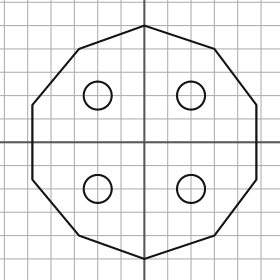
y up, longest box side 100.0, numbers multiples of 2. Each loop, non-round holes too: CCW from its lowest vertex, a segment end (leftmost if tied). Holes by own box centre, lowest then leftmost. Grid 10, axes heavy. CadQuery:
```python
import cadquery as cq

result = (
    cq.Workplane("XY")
    .moveTo(0.0, -50.0)
    .lineTo(30.0, -40.0)
    .lineTo(48.0, -16.0)
    .lineTo(48.0, 16.0)
    .lineTo(30.0, 40.0)
    .lineTo(0.0, 50.0)
    .lineTo(-28.0, 40.0)
    .lineTo(-48.0, 16.0)
    .lineTo(-48.0, -16.0)
    .lineTo(-28.0, -40.0)
    .close()
    .moveTo(-20.0, -20.0)
    .circle(6.0)
    .moveTo(20.0, -20.0)
    .circle(6.0)
    .moveTo(-20.0, 20.0)
    .circle(6.0)
    .moveTo(20.0, 20.0)
    .circle(6.0)
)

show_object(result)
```